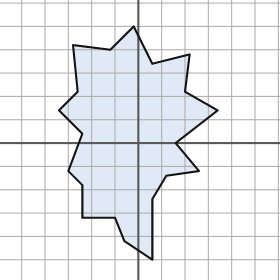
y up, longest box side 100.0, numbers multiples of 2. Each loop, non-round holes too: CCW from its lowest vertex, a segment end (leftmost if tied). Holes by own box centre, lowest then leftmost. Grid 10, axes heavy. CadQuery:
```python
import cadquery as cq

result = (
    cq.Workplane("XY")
    .moveTo(6.0, -50.0)
    .lineTo(6.0, -24.0)
    .lineTo(12.0, -14.0)
    .lineTo(26.0, -12.0)
    .lineTo(16.0, 0.0)
    .lineTo(34.0, 14.0)
    .lineTo(20.0, 22.0)
    .lineTo(22.0, 38.0)
    .lineTo(6.0, 34.0)
    .lineTo(-2.0, 50.0)
    .lineTo(-12.0, 40.0)
    .lineTo(-28.0, 42.0)
    .lineTo(-26.0, 22.0)
    .lineTo(-34.0, 14.0)
    .lineTo(-24.0, 4.0)
    .lineTo(-30.0, -12.0)
    .lineTo(-24.0, -18.0)
    .lineTo(-24.0, -32.0)
    .lineTo(-10.0, -32.0)
    .lineTo(-6.0, -42.0)
    .close()
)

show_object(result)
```